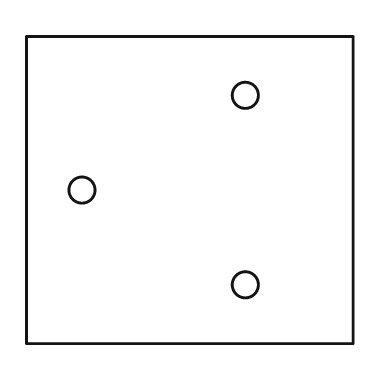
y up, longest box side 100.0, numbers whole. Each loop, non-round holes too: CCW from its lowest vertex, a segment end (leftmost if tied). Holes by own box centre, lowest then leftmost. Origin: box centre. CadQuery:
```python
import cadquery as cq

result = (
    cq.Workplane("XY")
    .moveTo(-50.0, -47.0)
    .lineTo(50.0, -47.0)
    .lineTo(50.0, 47.0)
    .lineTo(-50.0, 47.0)
    .close()
    .moveTo(17.0, -29.0)
    .circle(4.0)
    .moveTo(-33.0, 0.0)
    .circle(4.0)
    .moveTo(17.0, 29.0)
    .circle(4.0)
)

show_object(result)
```